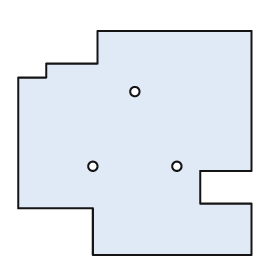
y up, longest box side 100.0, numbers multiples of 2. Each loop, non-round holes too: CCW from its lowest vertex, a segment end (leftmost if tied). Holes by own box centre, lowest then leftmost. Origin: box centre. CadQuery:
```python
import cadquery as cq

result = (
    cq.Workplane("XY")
    .moveTo(-18.0, -48.0)
    .lineTo(50.0, -48.0)
    .lineTo(50.0, -26.0)
    .lineTo(28.0, -26.0)
    .lineTo(28.0, -12.0)
    .lineTo(50.0, -12.0)
    .lineTo(50.0, 48.0)
    .lineTo(-16.0, 48.0)
    .lineTo(-16.0, 34.0)
    .lineTo(-38.0, 34.0)
    .lineTo(-38.0, 28.0)
    .lineTo(-50.0, 28.0)
    .lineTo(-50.0, -28.0)
    .lineTo(-18.0, -28.0)
    .close()
    .moveTo(-18.0, -10.0)
    .circle(2.0)
    .moveTo(18.0, -10.0)
    .circle(2.0)
    .moveTo(0.0, 22.0)
    .circle(2.0)
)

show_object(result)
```